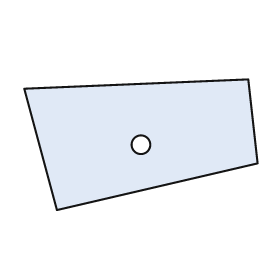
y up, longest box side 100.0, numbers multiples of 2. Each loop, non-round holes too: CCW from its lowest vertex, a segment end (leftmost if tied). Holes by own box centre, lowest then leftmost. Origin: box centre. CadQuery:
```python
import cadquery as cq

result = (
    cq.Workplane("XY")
    .moveTo(-36.0, -28.0)
    .lineTo(50.0, -8.0)
    .lineTo(46.0, 28.0)
    .lineTo(-50.0, 24.0)
    .close()
    .moveTo(0.0, 0.0)
    .circle(4.0)
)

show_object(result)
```